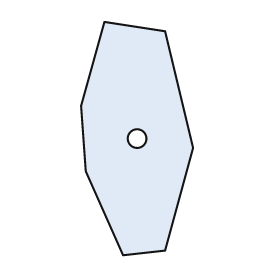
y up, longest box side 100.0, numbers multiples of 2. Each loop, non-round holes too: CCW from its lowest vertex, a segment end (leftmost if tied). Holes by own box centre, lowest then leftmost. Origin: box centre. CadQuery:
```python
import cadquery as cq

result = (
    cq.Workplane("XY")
    .moveTo(-6.0, -50.0)
    .lineTo(12.0, -48.0)
    .lineTo(24.0, -4.0)
    .lineTo(12.0, 46.0)
    .lineTo(-14.0, 50.0)
    .lineTo(-24.0, 14.0)
    .lineTo(-22.0, -14.0)
    .close()
    .moveTo(0.0, 0.0)
    .circle(4.0)
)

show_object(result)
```